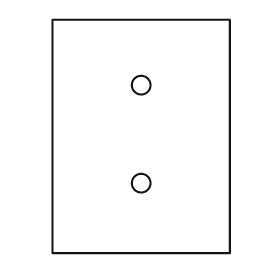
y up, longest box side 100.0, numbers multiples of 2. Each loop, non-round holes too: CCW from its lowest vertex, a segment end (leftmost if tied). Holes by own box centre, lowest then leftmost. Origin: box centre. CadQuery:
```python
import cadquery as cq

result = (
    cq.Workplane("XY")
    .moveTo(-38.0, -50.0)
    .lineTo(38.0, -50.0)
    .lineTo(38.0, 50.0)
    .lineTo(-38.0, 50.0)
    .close()
    .moveTo(0.0, -20.0)
    .circle(4.0)
    .moveTo(0.0, 22.0)
    .circle(4.0)
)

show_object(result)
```